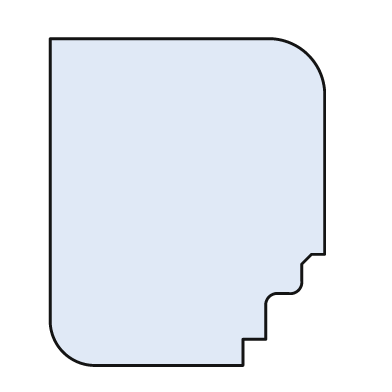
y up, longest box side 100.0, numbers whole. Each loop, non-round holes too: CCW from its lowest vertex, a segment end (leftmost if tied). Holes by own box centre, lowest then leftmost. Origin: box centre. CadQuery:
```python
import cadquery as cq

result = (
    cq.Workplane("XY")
    .moveTo(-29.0, -50.0)
    .lineTo(17.0, -50.0)
    .lineTo(17.0, -42.0)
    .lineTo(24.0, -42.0)
    .lineTo(24.0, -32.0)
    .threePointArc((25.0, -29.0), (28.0, -28.0))
    .lineTo(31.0, -28.0)
    .threePointArc((34.0, -27.0), (35.0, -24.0))
    .lineTo(35.0, -19.0)
    .lineTo(38.0, -16.0)
    .lineTo(42.0, -16.0)
    .lineTo(42.0, 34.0)
    .threePointArc((37.0, 45.0), (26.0, 50.0))
    .lineTo(-42.0, 50.0)
    .lineTo(-42.0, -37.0)
    .threePointArc((-38.0, -46.0), (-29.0, -50.0))
    .close()
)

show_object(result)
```